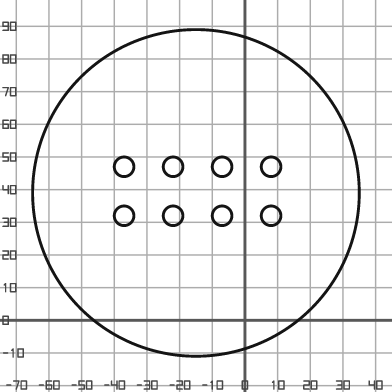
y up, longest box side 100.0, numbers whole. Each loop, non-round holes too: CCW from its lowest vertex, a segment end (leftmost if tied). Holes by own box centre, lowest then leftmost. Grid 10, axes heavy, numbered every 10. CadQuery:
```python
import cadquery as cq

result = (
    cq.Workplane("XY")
    .moveTo(-15.0, 39.0)
    .circle(50.0)
    .moveTo(-37.0, 32.0)
    .circle(3.0)
    .moveTo(-22.0, 32.0)
    .circle(3.0)
    .moveTo(-7.0, 32.0)
    .circle(3.0)
    .moveTo(8.0, 32.0)
    .circle(3.0)
    .moveTo(-37.0, 47.0)
    .circle(3.0)
    .moveTo(-22.0, 47.0)
    .circle(3.0)
    .moveTo(-7.0, 47.0)
    .circle(3.0)
    .moveTo(8.0, 47.0)
    .circle(3.0)
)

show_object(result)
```